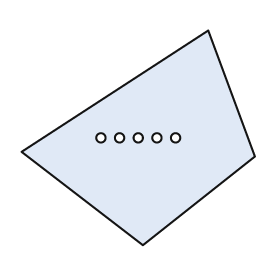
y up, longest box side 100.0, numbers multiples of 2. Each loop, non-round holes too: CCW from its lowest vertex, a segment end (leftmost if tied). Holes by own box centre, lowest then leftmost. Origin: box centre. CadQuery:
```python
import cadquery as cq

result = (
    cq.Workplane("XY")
    .moveTo(2.0, -46.0)
    .lineTo(50.0, -8.0)
    .lineTo(30.0, 46.0)
    .lineTo(-50.0, -6.0)
    .close()
    .moveTo(-16.0, 0.0)
    .circle(2.0)
    .moveTo(-8.0, 0.0)
    .circle(2.0)
    .moveTo(0.0, 0.0)
    .circle(2.0)
    .moveTo(8.0, 0.0)
    .circle(2.0)
    .moveTo(16.0, 0.0)
    .circle(2.0)
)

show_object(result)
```